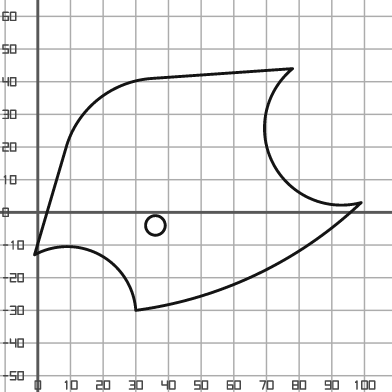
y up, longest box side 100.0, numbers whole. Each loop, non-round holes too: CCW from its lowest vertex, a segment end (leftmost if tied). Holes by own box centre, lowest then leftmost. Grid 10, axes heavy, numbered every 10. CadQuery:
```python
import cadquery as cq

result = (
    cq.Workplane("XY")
    .moveTo(30.0, -30.0)
    .threePointArc((67.0, -19.0), (99.0, 3.0))
    .threePointArc((72.0, 15.0), (78.0, 44.0))
    .lineTo(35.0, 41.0)
    .threePointArc((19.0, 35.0), (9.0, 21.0))
    .lineTo(-1.0, -13.0)
    .threePointArc((19.0, -13.0), (30.0, -30.0))
    .close()
    .moveTo(36.0, -4.0)
    .circle(3.0)
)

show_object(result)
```